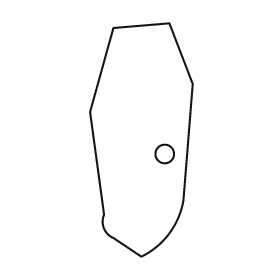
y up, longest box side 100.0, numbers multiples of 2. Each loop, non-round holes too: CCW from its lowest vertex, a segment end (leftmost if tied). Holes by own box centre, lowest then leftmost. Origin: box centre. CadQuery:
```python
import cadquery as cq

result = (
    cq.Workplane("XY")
    .moveTo(0.0, -50.0)
    .threePointArc((12.0, -40.0), (18.0, -26.0))
    .lineTo(22.0, 24.0)
    .lineTo(12.0, 50.0)
    .lineTo(-12.0, 48.0)
    .lineTo(-22.0, 12.0)
    .lineTo(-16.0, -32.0)
    .threePointArc((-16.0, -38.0), (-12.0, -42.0))
    .close()
    .moveTo(10.0, -6.0)
    .circle(4.0)
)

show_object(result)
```